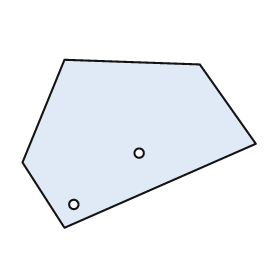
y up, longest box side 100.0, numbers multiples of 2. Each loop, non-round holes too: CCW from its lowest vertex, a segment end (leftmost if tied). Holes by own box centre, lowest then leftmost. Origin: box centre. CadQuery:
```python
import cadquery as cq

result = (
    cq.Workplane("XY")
    .moveTo(-32.0, -36.0)
    .lineTo(50.0, 0.0)
    .lineTo(26.0, 34.0)
    .lineTo(-32.0, 36.0)
    .lineTo(-50.0, -8.0)
    .close()
    .moveTo(-28.0, -26.0)
    .circle(2.0)
    .moveTo(0.0, -4.0)
    .circle(2.0)
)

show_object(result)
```